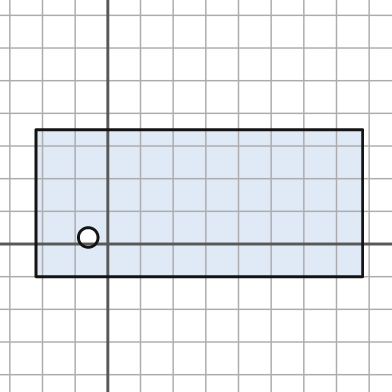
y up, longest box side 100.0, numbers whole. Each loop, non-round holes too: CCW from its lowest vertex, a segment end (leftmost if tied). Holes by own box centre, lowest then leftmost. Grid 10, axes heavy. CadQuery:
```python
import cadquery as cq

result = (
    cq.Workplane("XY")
    .moveTo(-22.0, -10.0)
    .lineTo(78.0, -10.0)
    .lineTo(78.0, 35.0)
    .lineTo(-22.0, 35.0)
    .close()
    .moveTo(-6.0, 2.0)
    .circle(3.0)
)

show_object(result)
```